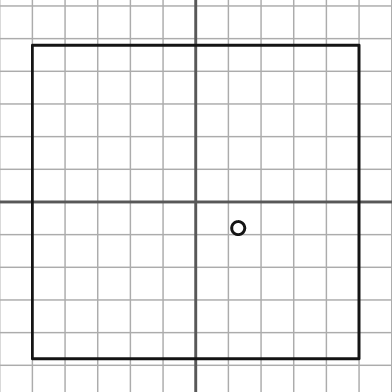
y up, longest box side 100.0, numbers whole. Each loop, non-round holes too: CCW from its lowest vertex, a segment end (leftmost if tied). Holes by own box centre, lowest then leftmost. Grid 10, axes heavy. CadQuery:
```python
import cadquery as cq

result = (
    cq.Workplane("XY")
    .moveTo(-50.0, -48.0)
    .lineTo(50.0, -48.0)
    .lineTo(50.0, 48.0)
    .lineTo(-50.0, 48.0)
    .close()
    .moveTo(13.0, -8.0)
    .circle(2.0)
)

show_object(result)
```